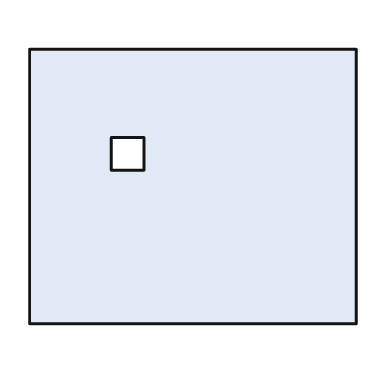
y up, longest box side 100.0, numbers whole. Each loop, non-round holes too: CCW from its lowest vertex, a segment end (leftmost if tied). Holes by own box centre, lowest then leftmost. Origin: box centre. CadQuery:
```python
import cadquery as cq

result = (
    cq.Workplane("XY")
    .moveTo(-50.0, -42.0)
    .lineTo(50.0, -42.0)
    .lineTo(50.0, 42.0)
    .lineTo(-50.0, 42.0)
    .close()
    .moveTo(-25.0, 5.0)
    .lineTo(-15.0, 5.0)
    .lineTo(-15.0, 15.0)
    .lineTo(-25.0, 15.0)
    .close()
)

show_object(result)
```